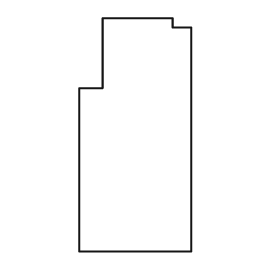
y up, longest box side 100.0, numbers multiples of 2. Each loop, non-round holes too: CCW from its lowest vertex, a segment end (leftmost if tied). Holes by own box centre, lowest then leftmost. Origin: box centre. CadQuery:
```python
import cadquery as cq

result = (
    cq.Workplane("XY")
    .moveTo(-24.0, -50.0)
    .lineTo(24.0, -50.0)
    .lineTo(24.0, 46.0)
    .lineTo(16.0, 46.0)
    .lineTo(16.0, 50.0)
    .lineTo(-14.0, 50.0)
    .lineTo(-14.0, 20.0)
    .lineTo(-24.0, 20.0)
    .close()
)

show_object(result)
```